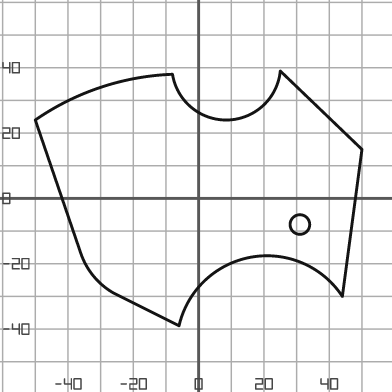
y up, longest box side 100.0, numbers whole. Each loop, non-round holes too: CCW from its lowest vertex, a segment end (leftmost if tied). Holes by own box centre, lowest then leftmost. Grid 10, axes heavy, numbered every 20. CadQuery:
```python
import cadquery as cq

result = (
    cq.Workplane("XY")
    .moveTo(-6.0, -39.0)
    .threePointArc((16.0, -18.0), (44.0, -30.0))
    .lineTo(50.0, 15.0)
    .lineTo(25.0, 39.0)
    .threePointArc((9.0, 24.0), (-8.0, 38.0))
    .threePointArc((-30.0, 34.0), (-50.0, 24.0))
    .lineTo(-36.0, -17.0)
    .threePointArc((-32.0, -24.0), (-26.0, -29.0))
    .close()
    .moveTo(31.0, -8.0)
    .circle(3.0)
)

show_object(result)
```